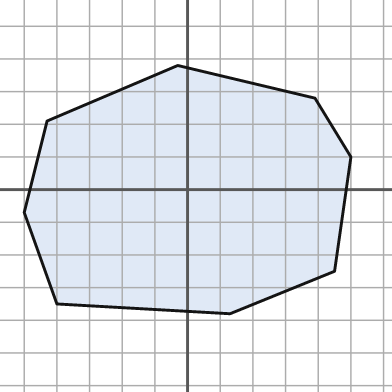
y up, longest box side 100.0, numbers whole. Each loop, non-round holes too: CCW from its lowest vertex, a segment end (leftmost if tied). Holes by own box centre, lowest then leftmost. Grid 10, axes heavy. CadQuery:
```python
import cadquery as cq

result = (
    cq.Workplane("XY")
    .moveTo(13.0, -38.0)
    .lineTo(45.0, -25.0)
    .lineTo(50.0, 10.0)
    .lineTo(39.0, 28.0)
    .lineTo(-3.0, 38.0)
    .lineTo(-43.0, 21.0)
    .lineTo(-50.0, -7.0)
    .lineTo(-40.0, -35.0)
    .close()
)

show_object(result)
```